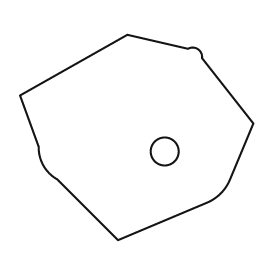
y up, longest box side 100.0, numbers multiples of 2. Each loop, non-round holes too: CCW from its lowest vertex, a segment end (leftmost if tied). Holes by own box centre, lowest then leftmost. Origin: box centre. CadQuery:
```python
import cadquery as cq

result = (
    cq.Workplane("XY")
    .moveTo(-8.0, -44.0)
    .lineTo(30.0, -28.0)
    .threePointArc((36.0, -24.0), (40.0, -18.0))
    .lineTo(50.0, 6.0)
    .lineTo(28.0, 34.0)
    .threePointArc((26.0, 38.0), (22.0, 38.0))
    .lineTo(-4.0, 44.0)
    .lineTo(-50.0, 18.0)
    .lineTo(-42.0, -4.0)
    .threePointArc((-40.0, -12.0), (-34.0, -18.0))
    .close()
    .moveTo(12.0, -6.0)
    .circle(6.0)
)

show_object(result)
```